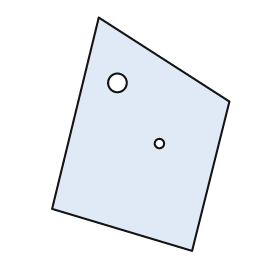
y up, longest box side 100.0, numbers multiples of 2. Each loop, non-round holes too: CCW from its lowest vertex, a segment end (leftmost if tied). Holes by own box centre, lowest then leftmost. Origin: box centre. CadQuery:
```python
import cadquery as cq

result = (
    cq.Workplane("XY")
    .moveTo(22.0, -50.0)
    .lineTo(38.0, 14.0)
    .lineTo(-18.0, 50.0)
    .lineTo(-38.0, -32.0)
    .close()
    .moveTo(8.0, -4.0)
    .circle(2.0)
    .moveTo(-10.0, 22.0)
    .circle(4.0)
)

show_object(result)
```